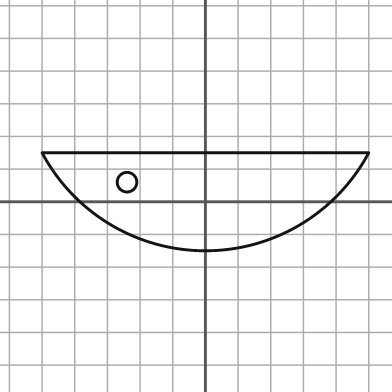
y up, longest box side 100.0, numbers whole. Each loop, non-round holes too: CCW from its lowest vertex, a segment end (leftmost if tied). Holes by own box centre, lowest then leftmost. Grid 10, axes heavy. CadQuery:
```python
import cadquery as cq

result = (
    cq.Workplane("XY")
    .moveTo(-50.0, 15.0)
    .threePointArc((0.0, -15.0), (50.0, 15.0))
    .close()
    .moveTo(-24.0, 6.0)
    .circle(3.0)
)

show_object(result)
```